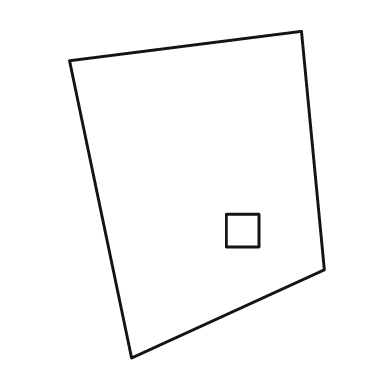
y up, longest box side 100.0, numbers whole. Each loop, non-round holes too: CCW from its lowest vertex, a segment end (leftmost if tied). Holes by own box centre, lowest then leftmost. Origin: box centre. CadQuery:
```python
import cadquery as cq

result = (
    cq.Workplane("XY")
    .moveTo(-20.0, -50.0)
    .lineTo(39.0, -23.0)
    .lineTo(32.0, 50.0)
    .lineTo(-39.0, 41.0)
    .close()
    .moveTo(9.0, -16.0)
    .lineTo(19.0, -16.0)
    .lineTo(19.0, -6.0)
    .lineTo(9.0, -6.0)
    .close()
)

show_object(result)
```